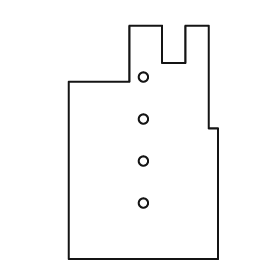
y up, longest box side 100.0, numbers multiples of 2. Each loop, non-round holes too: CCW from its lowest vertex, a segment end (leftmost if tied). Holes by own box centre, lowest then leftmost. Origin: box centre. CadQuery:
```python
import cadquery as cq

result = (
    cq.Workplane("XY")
    .moveTo(-32.0, -50.0)
    .lineTo(32.0, -50.0)
    .lineTo(32.0, 6.0)
    .lineTo(28.0, 6.0)
    .lineTo(28.0, 50.0)
    .lineTo(18.0, 50.0)
    .lineTo(18.0, 34.0)
    .lineTo(8.0, 34.0)
    .lineTo(8.0, 50.0)
    .lineTo(-6.0, 50.0)
    .lineTo(-6.0, 26.0)
    .lineTo(-32.0, 26.0)
    .close()
    .moveTo(0.0, -26.0)
    .circle(2.0)
    .moveTo(0.0, -8.0)
    .circle(2.0)
    .moveTo(0.0, 10.0)
    .circle(2.0)
    .moveTo(0.0, 28.0)
    .circle(2.0)
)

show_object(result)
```